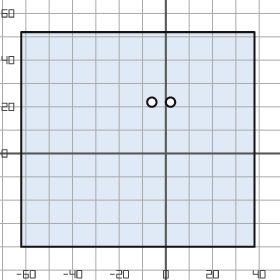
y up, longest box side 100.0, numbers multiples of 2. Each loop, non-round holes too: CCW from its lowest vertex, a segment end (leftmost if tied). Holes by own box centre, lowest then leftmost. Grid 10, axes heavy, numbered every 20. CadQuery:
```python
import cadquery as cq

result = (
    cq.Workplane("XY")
    .moveTo(-62.0, -40.0)
    .lineTo(38.0, -40.0)
    .lineTo(38.0, 52.0)
    .lineTo(-62.0, 52.0)
    .close()
    .moveTo(-6.0, 22.0)
    .circle(2.0)
    .moveTo(2.0, 22.0)
    .circle(2.0)
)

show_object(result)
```